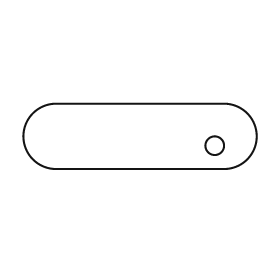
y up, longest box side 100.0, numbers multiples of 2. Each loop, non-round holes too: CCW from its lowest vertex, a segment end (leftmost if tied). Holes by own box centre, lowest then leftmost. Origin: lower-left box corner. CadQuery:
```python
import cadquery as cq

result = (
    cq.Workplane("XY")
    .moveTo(14.0, 0.0)
    .lineTo(86.0, 0.0)
    .threePointArc((100.0, 14.0), (86.0, 28.0))
    .lineTo(14.0, 28.0)
    .threePointArc((0.0, 14.0), (14.0, 0.0))
    .close()
    .moveTo(82.0, 10.0)
    .circle(4.0)
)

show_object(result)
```